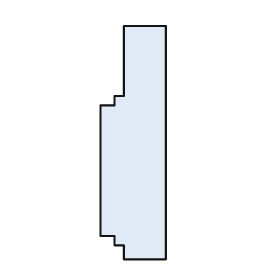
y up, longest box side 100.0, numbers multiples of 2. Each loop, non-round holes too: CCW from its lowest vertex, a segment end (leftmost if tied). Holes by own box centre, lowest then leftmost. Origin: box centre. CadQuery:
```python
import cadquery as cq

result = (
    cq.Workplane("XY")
    .moveTo(-4.0, -50.0)
    .lineTo(14.0, -50.0)
    .lineTo(14.0, 50.0)
    .lineTo(-4.0, 50.0)
    .lineTo(-4.0, 20.0)
    .lineTo(-8.0, 20.0)
    .lineTo(-8.0, 16.0)
    .lineTo(-14.0, 16.0)
    .lineTo(-14.0, -40.0)
    .lineTo(-8.0, -40.0)
    .lineTo(-8.0, -44.0)
    .lineTo(-4.0, -44.0)
    .close()
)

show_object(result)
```